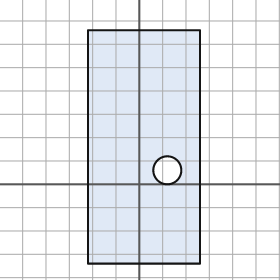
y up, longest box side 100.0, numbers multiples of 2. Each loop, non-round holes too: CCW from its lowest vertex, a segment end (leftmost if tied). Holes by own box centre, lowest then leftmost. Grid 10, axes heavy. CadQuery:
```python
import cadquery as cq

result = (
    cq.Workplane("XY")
    .moveTo(-22.0, -34.0)
    .lineTo(26.0, -34.0)
    .lineTo(26.0, 66.0)
    .lineTo(-22.0, 66.0)
    .close()
    .moveTo(12.0, 6.0)
    .circle(6.0)
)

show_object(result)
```